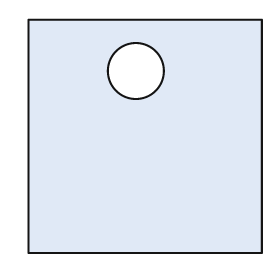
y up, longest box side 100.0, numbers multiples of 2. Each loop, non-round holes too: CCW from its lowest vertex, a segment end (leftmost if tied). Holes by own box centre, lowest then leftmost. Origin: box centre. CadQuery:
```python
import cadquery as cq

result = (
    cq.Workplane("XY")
    .moveTo(-50.0, -50.0)
    .lineTo(50.0, -50.0)
    .lineTo(50.0, 50.0)
    .lineTo(-50.0, 50.0)
    .close()
    .moveTo(-4.0, 28.0)
    .circle(12.0)
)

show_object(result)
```